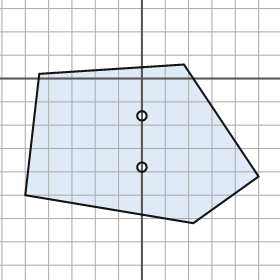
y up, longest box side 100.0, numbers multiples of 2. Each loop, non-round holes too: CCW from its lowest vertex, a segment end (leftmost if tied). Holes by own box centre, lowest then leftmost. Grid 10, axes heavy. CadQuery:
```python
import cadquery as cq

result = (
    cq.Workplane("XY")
    .moveTo(22.0, -62.0)
    .lineTo(50.0, -42.0)
    .lineTo(18.0, 6.0)
    .lineTo(-44.0, 2.0)
    .lineTo(-50.0, -50.0)
    .close()
    .moveTo(0.0, -38.0)
    .circle(2.0)
    .moveTo(0.0, -16.0)
    .circle(2.0)
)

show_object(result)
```